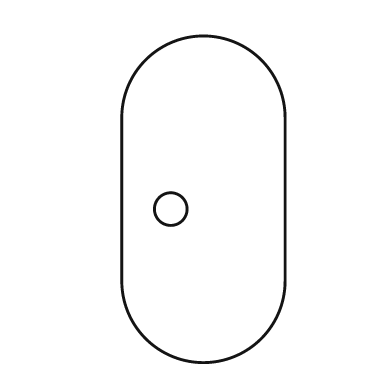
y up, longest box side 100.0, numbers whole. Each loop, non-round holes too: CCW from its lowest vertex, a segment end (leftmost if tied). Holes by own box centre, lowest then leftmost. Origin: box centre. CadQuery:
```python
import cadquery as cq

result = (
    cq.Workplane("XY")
    .moveTo(-25.0, -25.0)
    .threePointArc((0.0, -50.0), (25.0, -25.0))
    .lineTo(25.0, 25.0)
    .threePointArc((0.0, 50.0), (-25.0, 25.0))
    .close()
    .moveTo(-10.0, -3.0)
    .circle(5.0)
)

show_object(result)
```